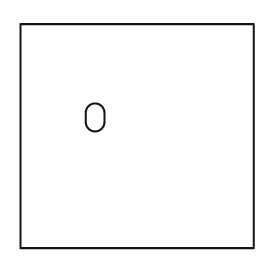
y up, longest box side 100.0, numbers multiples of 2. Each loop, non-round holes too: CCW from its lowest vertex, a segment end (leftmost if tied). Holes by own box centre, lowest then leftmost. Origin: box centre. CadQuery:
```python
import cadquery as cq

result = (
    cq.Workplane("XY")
    .moveTo(-50.0, -48.0)
    .lineTo(50.0, -48.0)
    .lineTo(50.0, 48.0)
    .lineTo(-50.0, 48.0)
    .close()
    .moveTo(-22.0, 6.0)
    .threePointArc((-18.0, 2.0), (-14.0, 6.0))
    .lineTo(-14.0, 10.0)
    .threePointArc((-18.0, 14.0), (-22.0, 10.0))
    .close()
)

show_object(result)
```